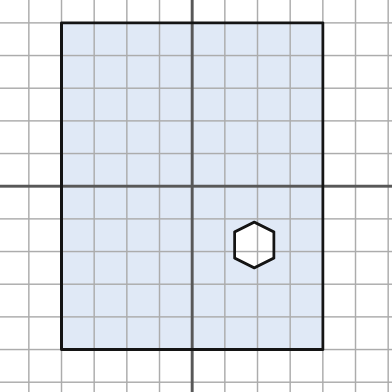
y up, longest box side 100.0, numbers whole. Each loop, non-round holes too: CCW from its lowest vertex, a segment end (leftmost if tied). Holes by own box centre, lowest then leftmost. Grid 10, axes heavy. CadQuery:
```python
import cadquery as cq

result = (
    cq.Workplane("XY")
    .moveTo(-40.0, -50.0)
    .lineTo(40.0, -50.0)
    .lineTo(40.0, 50.0)
    .lineTo(-40.0, 50.0)
    .close()
    .moveTo(19.0, -25.0)
    .lineTo(25.0, -22.0)
    .lineTo(25.0, -14.0)
    .lineTo(19.0, -11.0)
    .lineTo(13.0, -14.0)
    .lineTo(13.0, -22.0)
    .close()
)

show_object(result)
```